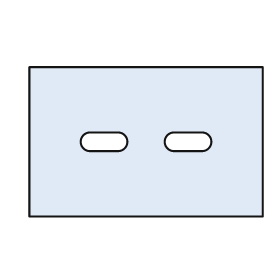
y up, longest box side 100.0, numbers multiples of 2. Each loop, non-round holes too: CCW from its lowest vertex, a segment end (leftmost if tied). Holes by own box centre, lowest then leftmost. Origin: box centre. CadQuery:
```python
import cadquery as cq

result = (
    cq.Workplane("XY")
    .moveTo(-50.0, -32.0)
    .lineTo(50.0, -32.0)
    .lineTo(50.0, 32.0)
    .lineTo(-50.0, 32.0)
    .close()
    .moveTo(-24.0, -4.0)
    .lineTo(-12.0, -4.0)
    .threePointArc((-8.0, 0.0), (-12.0, 4.0))
    .lineTo(-24.0, 4.0)
    .threePointArc((-28.0, 0.0), (-24.0, -4.0))
    .close()
    .moveTo(12.0, -4.0)
    .lineTo(24.0, -4.0)
    .threePointArc((28.0, 0.0), (24.0, 4.0))
    .lineTo(12.0, 4.0)
    .threePointArc((8.0, 0.0), (12.0, -4.0))
    .close()
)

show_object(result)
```